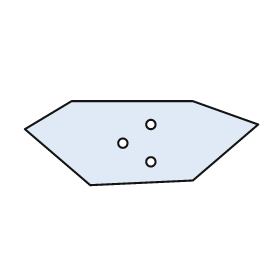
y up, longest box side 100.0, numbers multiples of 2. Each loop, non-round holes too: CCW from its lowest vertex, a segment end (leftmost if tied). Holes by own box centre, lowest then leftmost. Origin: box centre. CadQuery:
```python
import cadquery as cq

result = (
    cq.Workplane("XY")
    .moveTo(-22.0, -18.0)
    .lineTo(22.0, -16.0)
    .lineTo(50.0, 8.0)
    .lineTo(22.0, 18.0)
    .lineTo(-30.0, 18.0)
    .lineTo(-50.0, 6.0)
    .close()
    .moveTo(4.0, -8.0)
    .circle(2.0)
    .moveTo(-8.0, 0.0)
    .circle(2.0)
    .moveTo(4.0, 8.0)
    .circle(2.0)
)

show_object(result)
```